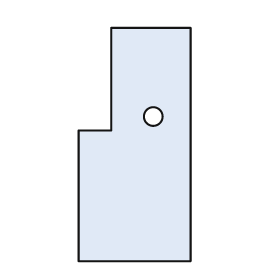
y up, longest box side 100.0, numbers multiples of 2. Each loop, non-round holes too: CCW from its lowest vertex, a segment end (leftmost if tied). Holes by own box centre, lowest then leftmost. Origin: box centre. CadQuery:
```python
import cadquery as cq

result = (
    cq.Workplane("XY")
    .moveTo(-24.0, -50.0)
    .lineTo(24.0, -50.0)
    .lineTo(24.0, 50.0)
    .lineTo(-10.0, 50.0)
    .lineTo(-10.0, 6.0)
    .lineTo(-24.0, 6.0)
    .close()
    .moveTo(8.0, 12.0)
    .circle(4.0)
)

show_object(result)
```